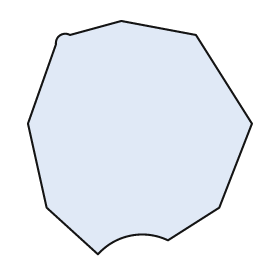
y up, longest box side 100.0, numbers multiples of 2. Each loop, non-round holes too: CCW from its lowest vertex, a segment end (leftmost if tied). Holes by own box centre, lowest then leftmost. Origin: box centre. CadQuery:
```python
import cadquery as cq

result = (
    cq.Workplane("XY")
    .moveTo(-18.0, -50.0)
    .threePointArc((-4.0, -42.0), (12.0, -44.0))
    .lineTo(34.0, -30.0)
    .lineTo(48.0, 6.0)
    .lineTo(24.0, 44.0)
    .lineTo(-8.0, 50.0)
    .lineTo(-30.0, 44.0)
    .threePointArc((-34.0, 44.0), (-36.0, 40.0))
    .lineTo(-48.0, 6.0)
    .lineTo(-40.0, -30.0)
    .close()
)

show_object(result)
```